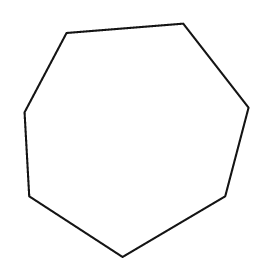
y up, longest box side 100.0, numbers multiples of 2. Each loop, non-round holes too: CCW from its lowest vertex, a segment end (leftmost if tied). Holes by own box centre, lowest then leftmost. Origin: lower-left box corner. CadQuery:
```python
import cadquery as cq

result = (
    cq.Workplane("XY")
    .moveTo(42.0, 0.0)
    .lineTo(86.0, 26.0)
    .lineTo(96.0, 64.0)
    .lineTo(68.0, 100.0)
    .lineTo(18.0, 96.0)
    .lineTo(0.0, 62.0)
    .lineTo(2.0, 26.0)
    .close()
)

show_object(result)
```